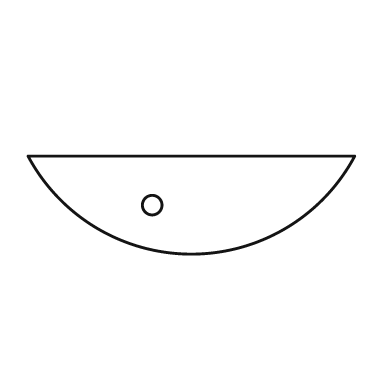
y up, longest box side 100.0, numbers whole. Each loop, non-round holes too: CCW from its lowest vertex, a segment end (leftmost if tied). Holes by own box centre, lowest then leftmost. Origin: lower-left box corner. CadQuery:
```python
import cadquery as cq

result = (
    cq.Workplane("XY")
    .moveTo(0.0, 30.0)
    .threePointArc((50.0, 0.0), (100.0, 30.0))
    .close()
    .moveTo(38.0, 15.0)
    .circle(3.0)
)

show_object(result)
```